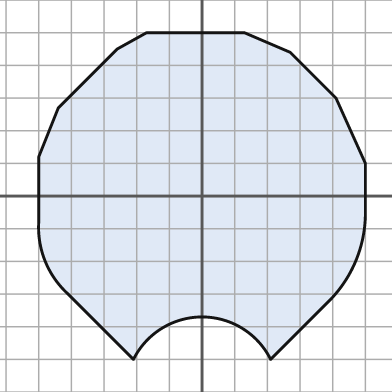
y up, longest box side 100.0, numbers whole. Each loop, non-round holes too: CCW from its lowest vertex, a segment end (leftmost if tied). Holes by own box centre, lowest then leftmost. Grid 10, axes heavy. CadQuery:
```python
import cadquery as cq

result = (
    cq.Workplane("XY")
    .moveTo(-21.0, -50.0)
    .threePointArc((0.0, -37.0), (21.0, -50.0))
    .lineTo(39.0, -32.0)
    .threePointArc((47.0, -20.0), (50.0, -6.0))
    .lineTo(50.0, 10.0)
    .lineTo(41.0, 30.0)
    .lineTo(27.0, 44.0)
    .lineTo(13.0, 50.0)
    .lineTo(-17.0, 50.0)
    .lineTo(-26.0, 45.0)
    .lineTo(-44.0, 27.0)
    .lineTo(-50.0, 12.0)
    .lineTo(-50.0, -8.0)
    .threePointArc((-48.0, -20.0), (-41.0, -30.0))
    .close()
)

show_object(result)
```